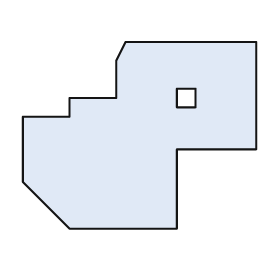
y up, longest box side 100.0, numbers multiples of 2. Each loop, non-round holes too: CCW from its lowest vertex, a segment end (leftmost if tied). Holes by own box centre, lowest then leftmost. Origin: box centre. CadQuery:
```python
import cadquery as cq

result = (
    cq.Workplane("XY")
    .moveTo(-30.0, -40.0)
    .lineTo(16.0, -40.0)
    .lineTo(16.0, -6.0)
    .lineTo(50.0, -6.0)
    .lineTo(50.0, 40.0)
    .lineTo(-6.0, 40.0)
    .lineTo(-10.0, 32.0)
    .lineTo(-10.0, 16.0)
    .lineTo(-30.0, 16.0)
    .lineTo(-30.0, 8.0)
    .lineTo(-50.0, 8.0)
    .lineTo(-50.0, -20.0)
    .close()
    .moveTo(16.0, 12.0)
    .lineTo(24.0, 12.0)
    .lineTo(24.0, 20.0)
    .lineTo(16.0, 20.0)
    .close()
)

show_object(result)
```